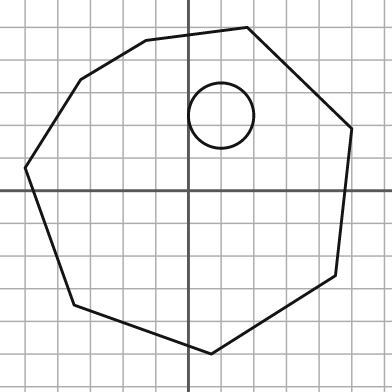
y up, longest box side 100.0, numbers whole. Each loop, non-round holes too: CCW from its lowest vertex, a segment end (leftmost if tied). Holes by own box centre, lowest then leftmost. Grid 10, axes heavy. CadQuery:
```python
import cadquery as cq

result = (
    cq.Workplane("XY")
    .moveTo(7.0, -50.0)
    .lineTo(45.0, -26.0)
    .lineTo(50.0, 19.0)
    .lineTo(18.0, 50.0)
    .lineTo(-13.0, 46.0)
    .lineTo(-33.0, 34.0)
    .lineTo(-50.0, 7.0)
    .lineTo(-35.0, -35.0)
    .close()
    .moveTo(10.0, 23.0)
    .circle(10.0)
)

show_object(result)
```